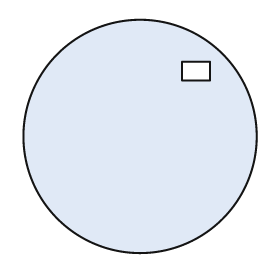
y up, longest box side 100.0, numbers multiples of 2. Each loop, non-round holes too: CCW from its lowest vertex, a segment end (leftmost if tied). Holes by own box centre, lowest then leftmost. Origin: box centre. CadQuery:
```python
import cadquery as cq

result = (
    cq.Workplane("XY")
    .moveTo(0.0, 0.0)
    .circle(50.0)
    .moveTo(18.0, 24.0)
    .lineTo(30.0, 24.0)
    .lineTo(30.0, 32.0)
    .lineTo(18.0, 32.0)
    .close()
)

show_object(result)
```